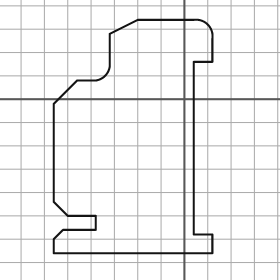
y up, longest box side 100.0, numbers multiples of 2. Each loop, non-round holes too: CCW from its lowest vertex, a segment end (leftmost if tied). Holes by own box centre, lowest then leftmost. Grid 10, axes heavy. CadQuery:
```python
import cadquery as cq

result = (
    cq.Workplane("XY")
    .moveTo(-56.0, -66.0)
    .lineTo(12.0, -66.0)
    .lineTo(12.0, -58.0)
    .lineTo(4.0, -58.0)
    .lineTo(4.0, 16.0)
    .lineTo(12.0, 16.0)
    .lineTo(12.0, 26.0)
    .threePointArc((10.0, 32.0), (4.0, 34.0))
    .lineTo(-20.0, 34.0)
    .lineTo(-32.0, 28.0)
    .lineTo(-32.0, 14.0)
    .threePointArc((-34.0, 10.0), (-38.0, 8.0))
    .lineTo(-46.0, 8.0)
    .lineTo(-56.0, -2.0)
    .lineTo(-56.0, -44.0)
    .lineTo(-50.0, -50.0)
    .lineTo(-38.0, -50.0)
    .lineTo(-38.0, -56.0)
    .lineTo(-52.0, -56.0)
    .lineTo(-56.0, -60.0)
    .close()
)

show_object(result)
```